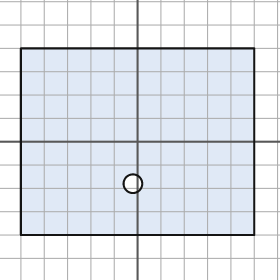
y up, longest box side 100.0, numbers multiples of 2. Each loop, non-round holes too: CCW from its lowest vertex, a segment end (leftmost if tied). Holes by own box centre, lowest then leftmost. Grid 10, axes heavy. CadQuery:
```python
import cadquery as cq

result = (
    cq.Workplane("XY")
    .moveTo(-50.0, -40.0)
    .lineTo(50.0, -40.0)
    .lineTo(50.0, 40.0)
    .lineTo(-50.0, 40.0)
    .close()
    .moveTo(-2.0, -18.0)
    .circle(4.0)
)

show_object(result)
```